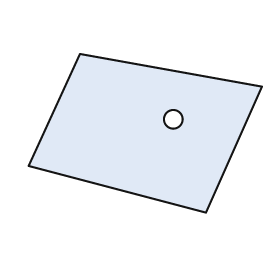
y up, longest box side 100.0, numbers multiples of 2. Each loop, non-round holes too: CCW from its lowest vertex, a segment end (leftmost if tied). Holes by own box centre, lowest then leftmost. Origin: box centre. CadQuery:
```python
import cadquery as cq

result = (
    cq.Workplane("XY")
    .moveTo(26.0, -34.0)
    .lineTo(50.0, 20.0)
    .lineTo(-28.0, 34.0)
    .lineTo(-50.0, -14.0)
    .close()
    .moveTo(12.0, 6.0)
    .circle(4.0)
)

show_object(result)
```